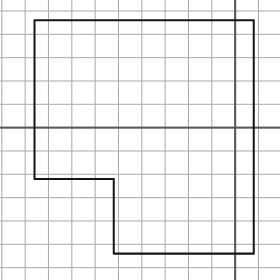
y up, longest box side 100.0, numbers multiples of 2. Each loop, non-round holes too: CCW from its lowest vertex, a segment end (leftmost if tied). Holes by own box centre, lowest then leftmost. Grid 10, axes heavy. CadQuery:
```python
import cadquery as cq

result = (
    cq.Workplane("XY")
    .moveTo(-52.0, -54.0)
    .lineTo(8.0, -54.0)
    .lineTo(8.0, 46.0)
    .lineTo(-86.0, 46.0)
    .lineTo(-86.0, -22.0)
    .lineTo(-52.0, -22.0)
    .close()
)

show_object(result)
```